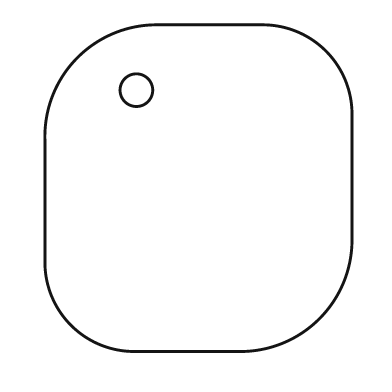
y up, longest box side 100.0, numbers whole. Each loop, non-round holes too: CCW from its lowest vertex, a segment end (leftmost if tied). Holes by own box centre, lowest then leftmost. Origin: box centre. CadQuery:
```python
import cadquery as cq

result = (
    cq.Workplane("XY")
    .moveTo(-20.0, -50.0)
    .lineTo(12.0, -50.0)
    .threePointArc((37.0, -40.0), (47.0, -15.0))
    .lineTo(47.0, 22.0)
    .threePointArc((39.0, 42.0), (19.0, 50.0))
    .lineTo(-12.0, 50.0)
    .threePointArc((-37.0, 40.0), (-47.0, 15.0))
    .lineTo(-47.0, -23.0)
    .threePointArc((-39.0, -42.0), (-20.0, -50.0))
    .close()
    .moveTo(-19.0, 30.0)
    .circle(5.0)
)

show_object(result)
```